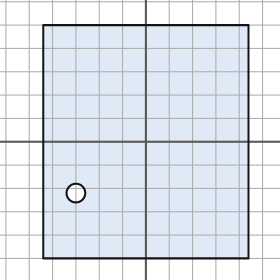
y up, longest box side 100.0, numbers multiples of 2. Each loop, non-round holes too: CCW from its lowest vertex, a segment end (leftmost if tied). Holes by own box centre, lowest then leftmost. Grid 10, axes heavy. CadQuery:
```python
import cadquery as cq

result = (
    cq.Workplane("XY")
    .moveTo(-44.0, -50.0)
    .lineTo(44.0, -50.0)
    .lineTo(44.0, 50.0)
    .lineTo(-44.0, 50.0)
    .close()
    .moveTo(-30.0, -22.0)
    .circle(4.0)
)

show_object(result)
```